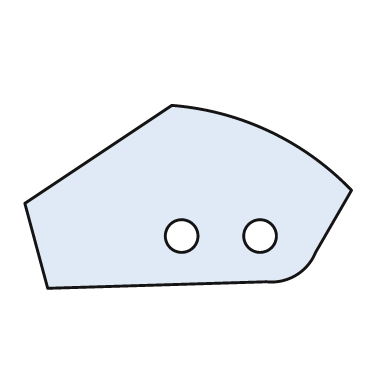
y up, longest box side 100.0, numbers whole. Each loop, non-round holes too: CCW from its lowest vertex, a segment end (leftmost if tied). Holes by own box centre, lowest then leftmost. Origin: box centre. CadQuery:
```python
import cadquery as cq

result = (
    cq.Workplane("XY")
    .moveTo(-43.0, -28.0)
    .lineTo(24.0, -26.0)
    .threePointArc((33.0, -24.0), (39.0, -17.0))
    .lineTo(50.0, 2.0)
    .threePointArc((25.0, 20.0), (-5.0, 28.0))
    .lineTo(-50.0, -2.0)
    .close()
    .moveTo(-2.0, -12.0)
    .circle(5.0)
    .moveTo(22.0, -12.0)
    .circle(5.0)
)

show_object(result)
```